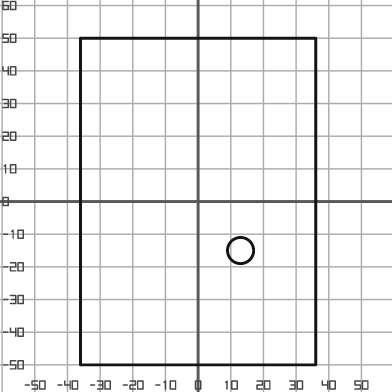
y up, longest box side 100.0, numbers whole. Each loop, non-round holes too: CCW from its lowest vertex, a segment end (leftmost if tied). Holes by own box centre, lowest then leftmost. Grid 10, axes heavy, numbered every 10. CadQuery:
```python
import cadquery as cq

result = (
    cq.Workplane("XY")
    .moveTo(-36.0, -50.0)
    .lineTo(36.0, -50.0)
    .lineTo(36.0, 50.0)
    .lineTo(-36.0, 50.0)
    .close()
    .moveTo(13.0, -15.0)
    .circle(4.0)
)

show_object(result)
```